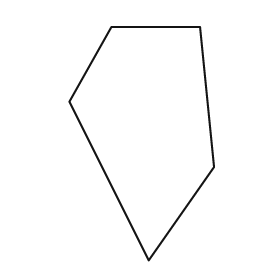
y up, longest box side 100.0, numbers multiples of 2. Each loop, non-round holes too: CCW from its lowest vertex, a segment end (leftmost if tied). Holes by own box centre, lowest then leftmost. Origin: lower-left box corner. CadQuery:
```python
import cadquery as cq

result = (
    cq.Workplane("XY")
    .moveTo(34.0, 0.0)
    .lineTo(62.0, 40.0)
    .lineTo(56.0, 100.0)
    .lineTo(18.0, 100.0)
    .lineTo(0.0, 68.0)
    .close()
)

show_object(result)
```